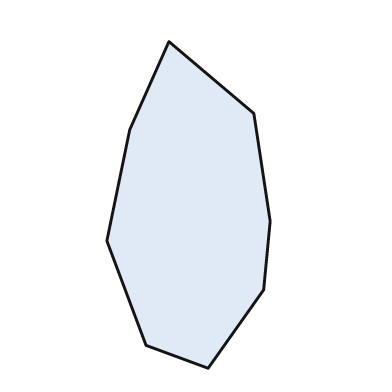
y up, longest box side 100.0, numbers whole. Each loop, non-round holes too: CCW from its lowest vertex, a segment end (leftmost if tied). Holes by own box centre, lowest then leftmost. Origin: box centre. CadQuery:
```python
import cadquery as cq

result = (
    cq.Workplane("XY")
    .moveTo(6.0, -50.0)
    .lineTo(23.0, -26.0)
    .lineTo(25.0, -5.0)
    .lineTo(20.0, 28.0)
    .lineTo(-6.0, 50.0)
    .lineTo(-18.0, 23.0)
    .lineTo(-25.0, -11.0)
    .lineTo(-13.0, -43.0)
    .close()
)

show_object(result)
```